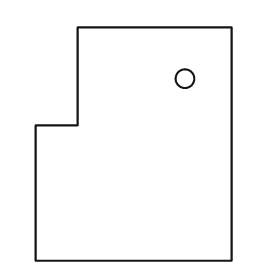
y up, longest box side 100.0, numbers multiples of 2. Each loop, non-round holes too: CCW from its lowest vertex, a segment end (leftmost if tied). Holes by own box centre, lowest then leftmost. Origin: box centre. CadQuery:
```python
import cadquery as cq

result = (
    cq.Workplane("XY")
    .moveTo(-42.0, -50.0)
    .lineTo(42.0, -50.0)
    .lineTo(42.0, 50.0)
    .lineTo(-24.0, 50.0)
    .lineTo(-24.0, 8.0)
    .lineTo(-42.0, 8.0)
    .close()
    .moveTo(22.0, 28.0)
    .circle(4.0)
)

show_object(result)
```